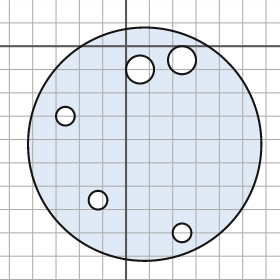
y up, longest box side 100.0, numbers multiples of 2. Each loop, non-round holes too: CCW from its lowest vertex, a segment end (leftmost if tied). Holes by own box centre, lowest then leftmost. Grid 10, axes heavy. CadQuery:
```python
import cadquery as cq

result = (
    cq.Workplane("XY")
    .moveTo(8.0, -42.0)
    .circle(50.0)
    .moveTo(24.0, -80.0)
    .circle(4.0)
    .moveTo(-12.0, -66.0)
    .circle(4.0)
    .moveTo(-26.0, -30.0)
    .circle(4.0)
    .moveTo(6.0, -10.0)
    .circle(6.0)
    .moveTo(24.0, -6.0)
    .circle(6.0)
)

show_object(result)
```